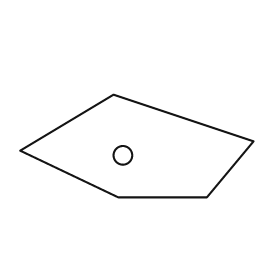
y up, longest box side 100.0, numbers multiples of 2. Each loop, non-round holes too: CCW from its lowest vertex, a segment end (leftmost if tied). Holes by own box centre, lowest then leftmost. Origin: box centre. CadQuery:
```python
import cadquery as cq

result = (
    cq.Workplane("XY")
    .moveTo(-8.0, -22.0)
    .lineTo(30.0, -22.0)
    .lineTo(50.0, 2.0)
    .lineTo(-10.0, 22.0)
    .lineTo(-50.0, -2.0)
    .close()
    .moveTo(-6.0, -4.0)
    .circle(4.0)
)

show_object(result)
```